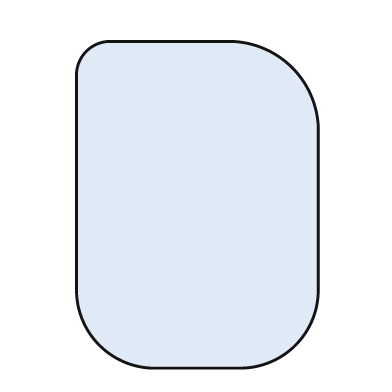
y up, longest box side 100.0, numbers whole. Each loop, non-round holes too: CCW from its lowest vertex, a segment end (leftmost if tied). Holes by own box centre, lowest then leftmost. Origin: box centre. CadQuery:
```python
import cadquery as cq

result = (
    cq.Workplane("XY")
    .moveTo(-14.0, -50.0)
    .lineTo(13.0, -50.0)
    .threePointArc((30.0, -43.0), (37.0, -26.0))
    .lineTo(37.0, 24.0)
    .threePointArc((29.0, 42.0), (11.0, 50.0))
    .lineTo(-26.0, 50.0)
    .threePointArc((-34.0, 47.0), (-37.0, 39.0))
    .lineTo(-37.0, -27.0)
    .threePointArc((-30.0, -43.0), (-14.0, -50.0))
    .close()
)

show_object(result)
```